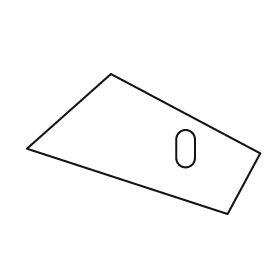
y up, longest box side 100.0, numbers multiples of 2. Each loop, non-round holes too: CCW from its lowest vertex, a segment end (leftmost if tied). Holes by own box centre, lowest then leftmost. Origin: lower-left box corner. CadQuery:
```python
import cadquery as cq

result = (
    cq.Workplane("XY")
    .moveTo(86.0, 0.0)
    .lineTo(100.0, 26.0)
    .lineTo(36.0, 60.0)
    .lineTo(0.0, 28.0)
    .close()
    .moveTo(64.0, 24.0)
    .threePointArc((68.0, 20.0), (72.0, 24.0))
    .lineTo(72.0, 32.0)
    .threePointArc((68.0, 36.0), (64.0, 32.0))
    .close()
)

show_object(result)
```